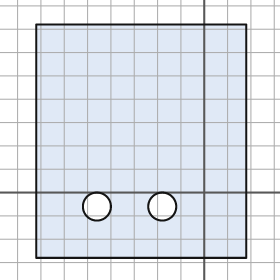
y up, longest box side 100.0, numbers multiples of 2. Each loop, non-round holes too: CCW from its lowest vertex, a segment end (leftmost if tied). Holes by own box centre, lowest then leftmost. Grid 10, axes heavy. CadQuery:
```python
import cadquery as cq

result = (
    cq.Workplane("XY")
    .moveTo(-72.0, -28.0)
    .lineTo(18.0, -28.0)
    .lineTo(18.0, 72.0)
    .lineTo(-72.0, 72.0)
    .close()
    .moveTo(-46.0, -6.0)
    .circle(6.0)
    .moveTo(-18.0, -6.0)
    .circle(6.0)
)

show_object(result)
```